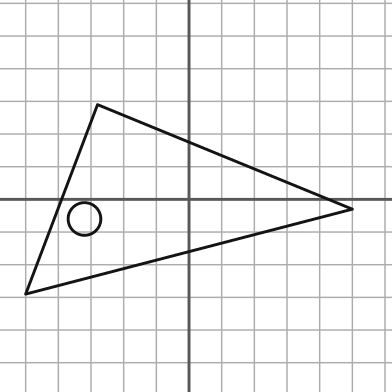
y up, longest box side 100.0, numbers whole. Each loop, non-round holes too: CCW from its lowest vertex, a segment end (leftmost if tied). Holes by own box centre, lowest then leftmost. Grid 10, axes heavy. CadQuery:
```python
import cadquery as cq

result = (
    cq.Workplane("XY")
    .moveTo(-50.0, -29.0)
    .lineTo(50.0, -3.0)
    .lineTo(-28.0, 29.0)
    .close()
    .moveTo(-32.0, -6.0)
    .circle(5.0)
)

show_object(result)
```